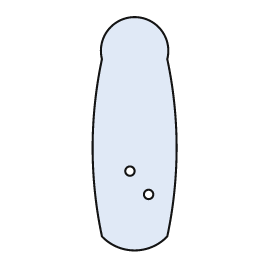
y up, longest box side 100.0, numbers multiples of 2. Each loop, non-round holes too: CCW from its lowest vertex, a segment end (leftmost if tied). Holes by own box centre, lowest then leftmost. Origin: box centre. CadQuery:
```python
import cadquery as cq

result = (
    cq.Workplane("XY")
    .moveTo(-14.0, -44.0)
    .threePointArc((0.0, -50.0), (14.0, -44.0))
    .threePointArc((18.0, -6.0), (14.0, 32.0))
    .threePointArc((0.0, 50.0), (-14.0, 32.0))
    .threePointArc((-18.0, -6.0), (-14.0, -44.0))
    .close()
    .moveTo(6.0, -26.0)
    .circle(2.0)
    .moveTo(-2.0, -16.0)
    .circle(2.0)
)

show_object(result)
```